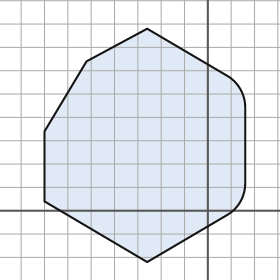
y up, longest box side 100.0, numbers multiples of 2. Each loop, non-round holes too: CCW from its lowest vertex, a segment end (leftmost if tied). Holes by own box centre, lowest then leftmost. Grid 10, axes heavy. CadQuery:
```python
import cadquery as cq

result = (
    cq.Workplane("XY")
    .moveTo(-26.0, -22.0)
    .lineTo(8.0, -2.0)
    .threePointArc((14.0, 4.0), (16.0, 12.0))
    .lineTo(16.0, 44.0)
    .threePointArc((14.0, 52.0), (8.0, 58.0))
    .lineTo(-26.0, 78.0)
    .lineTo(-52.0, 64.0)
    .lineTo(-70.0, 34.0)
    .lineTo(-70.0, 4.0)
    .close()
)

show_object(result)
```